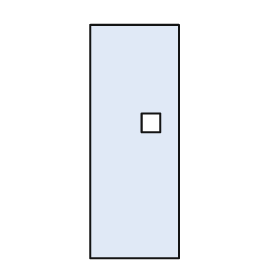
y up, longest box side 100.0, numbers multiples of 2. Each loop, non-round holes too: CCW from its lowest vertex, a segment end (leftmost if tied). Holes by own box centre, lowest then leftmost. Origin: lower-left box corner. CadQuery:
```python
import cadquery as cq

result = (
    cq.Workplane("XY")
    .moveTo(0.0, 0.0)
    .lineTo(38.0, 0.0)
    .lineTo(38.0, 100.0)
    .lineTo(0.0, 100.0)
    .close()
    .moveTo(22.0, 54.0)
    .lineTo(30.0, 54.0)
    .lineTo(30.0, 62.0)
    .lineTo(22.0, 62.0)
    .close()
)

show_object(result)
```